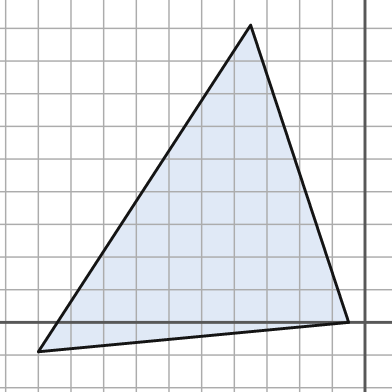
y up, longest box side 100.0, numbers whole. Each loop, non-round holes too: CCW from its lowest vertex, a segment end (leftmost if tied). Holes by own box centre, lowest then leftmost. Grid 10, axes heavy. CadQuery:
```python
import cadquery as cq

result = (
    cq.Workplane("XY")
    .moveTo(-100.0, -9.0)
    .lineTo(-5.0, 0.0)
    .lineTo(-35.0, 91.0)
    .close()
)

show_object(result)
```